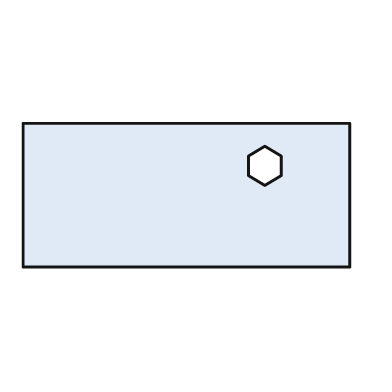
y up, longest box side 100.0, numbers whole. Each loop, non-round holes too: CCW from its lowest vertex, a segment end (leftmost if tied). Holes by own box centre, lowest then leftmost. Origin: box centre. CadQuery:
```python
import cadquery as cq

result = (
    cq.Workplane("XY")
    .moveTo(-50.0, -22.0)
    .lineTo(50.0, -22.0)
    .lineTo(50.0, 22.0)
    .lineTo(-50.0, 22.0)
    .close()
    .moveTo(24.0, 3.0)
    .lineTo(29.0, 6.0)
    .lineTo(29.0, 12.0)
    .lineTo(24.0, 15.0)
    .lineTo(19.0, 12.0)
    .lineTo(19.0, 6.0)
    .close()
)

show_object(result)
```